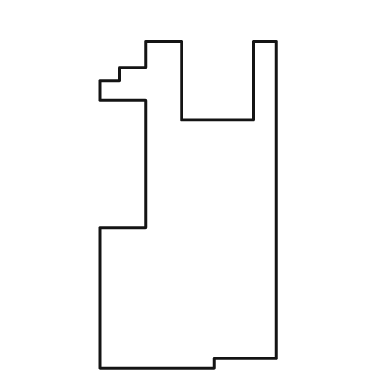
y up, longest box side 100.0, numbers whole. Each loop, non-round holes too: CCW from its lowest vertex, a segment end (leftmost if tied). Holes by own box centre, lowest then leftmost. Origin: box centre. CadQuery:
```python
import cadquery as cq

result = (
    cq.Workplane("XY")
    .moveTo(-27.0, -50.0)
    .lineTo(8.0, -50.0)
    .lineTo(8.0, -47.0)
    .lineTo(27.0, -47.0)
    .lineTo(27.0, 50.0)
    .lineTo(20.0, 50.0)
    .lineTo(20.0, 26.0)
    .lineTo(-2.0, 26.0)
    .lineTo(-2.0, 50.0)
    .lineTo(-13.0, 50.0)
    .lineTo(-13.0, 42.0)
    .lineTo(-21.0, 42.0)
    .lineTo(-21.0, 38.0)
    .lineTo(-27.0, 38.0)
    .lineTo(-27.0, 32.0)
    .lineTo(-13.0, 32.0)
    .lineTo(-13.0, -7.0)
    .lineTo(-27.0, -7.0)
    .close()
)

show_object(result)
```